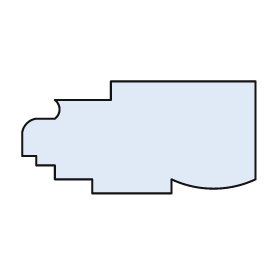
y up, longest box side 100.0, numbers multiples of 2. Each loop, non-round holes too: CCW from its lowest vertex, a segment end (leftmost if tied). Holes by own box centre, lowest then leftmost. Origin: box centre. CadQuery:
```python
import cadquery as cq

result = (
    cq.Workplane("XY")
    .moveTo(-20.0, -24.0)
    .lineTo(14.0, -24.0)
    .lineTo(14.0, -18.0)
    .threePointArc((32.0, -22.0), (50.0, -18.0))
    .lineTo(50.0, 24.0)
    .lineTo(-12.0, 24.0)
    .lineTo(-12.0, 16.0)
    .lineTo(-36.0, 16.0)
    .threePointArc((-34.0, 12.0), (-36.0, 8.0))
    .lineTo(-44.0, 8.0)
    .threePointArc((-48.0, 6.0), (-50.0, 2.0))
    .lineTo(-50.0, -8.0)
    .lineTo(-44.0, -8.0)
    .lineTo(-44.0, -12.0)
    .lineTo(-36.0, -12.0)
    .lineTo(-36.0, -18.0)
    .lineTo(-20.0, -18.0)
    .close()
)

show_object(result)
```